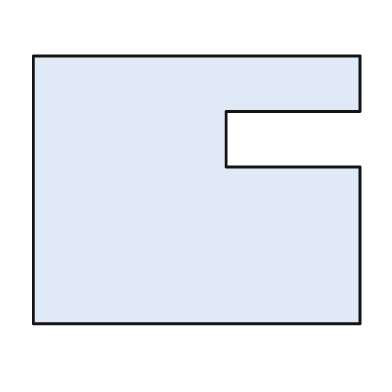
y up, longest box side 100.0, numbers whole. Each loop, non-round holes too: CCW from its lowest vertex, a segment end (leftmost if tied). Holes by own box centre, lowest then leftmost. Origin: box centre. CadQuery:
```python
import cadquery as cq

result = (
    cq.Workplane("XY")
    .moveTo(-50.0, -41.0)
    .lineTo(50.0, -41.0)
    .lineTo(50.0, 7.0)
    .lineTo(9.0, 7.0)
    .lineTo(9.0, 24.0)
    .lineTo(50.0, 24.0)
    .lineTo(50.0, 41.0)
    .lineTo(-50.0, 41.0)
    .close()
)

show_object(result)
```